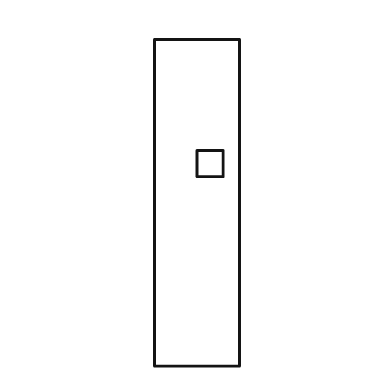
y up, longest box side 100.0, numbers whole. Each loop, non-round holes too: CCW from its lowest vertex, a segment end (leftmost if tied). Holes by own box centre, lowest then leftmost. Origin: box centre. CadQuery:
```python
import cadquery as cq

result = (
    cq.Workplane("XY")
    .moveTo(-13.0, -50.0)
    .lineTo(13.0, -50.0)
    .lineTo(13.0, 50.0)
    .lineTo(-13.0, 50.0)
    .close()
    .moveTo(0.0, 8.0)
    .lineTo(8.0, 8.0)
    .lineTo(8.0, 16.0)
    .lineTo(0.0, 16.0)
    .close()
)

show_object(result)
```